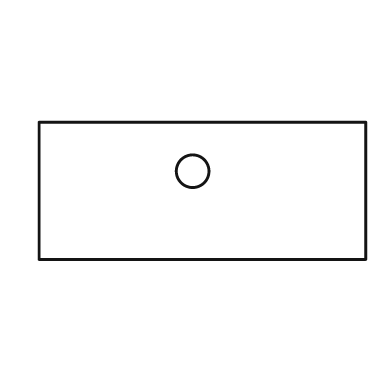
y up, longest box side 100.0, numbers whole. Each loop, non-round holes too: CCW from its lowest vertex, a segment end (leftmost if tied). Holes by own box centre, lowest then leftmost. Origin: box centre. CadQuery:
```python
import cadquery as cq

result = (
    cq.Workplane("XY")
    .moveTo(-50.0, -21.0)
    .lineTo(50.0, -21.0)
    .lineTo(50.0, 21.0)
    .lineTo(-50.0, 21.0)
    .close()
    .moveTo(-3.0, 6.0)
    .circle(5.0)
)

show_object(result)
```